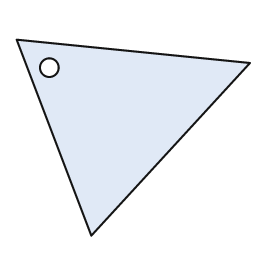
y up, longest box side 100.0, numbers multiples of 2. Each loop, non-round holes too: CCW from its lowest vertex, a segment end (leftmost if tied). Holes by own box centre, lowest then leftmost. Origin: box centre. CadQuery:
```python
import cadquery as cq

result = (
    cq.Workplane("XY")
    .moveTo(-18.0, -42.0)
    .lineTo(50.0, 32.0)
    .lineTo(-50.0, 42.0)
    .close()
    .moveTo(-36.0, 30.0)
    .circle(4.0)
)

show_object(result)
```